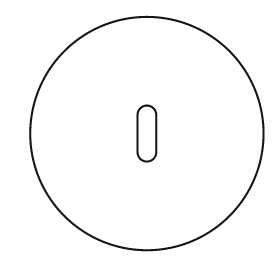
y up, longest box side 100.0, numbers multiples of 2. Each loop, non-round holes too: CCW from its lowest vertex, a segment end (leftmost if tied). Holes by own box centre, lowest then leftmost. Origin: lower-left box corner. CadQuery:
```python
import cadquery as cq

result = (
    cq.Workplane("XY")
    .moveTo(50.0, 50.0)
    .circle(50.0)
    .moveTo(46.0, 42.0)
    .threePointArc((50.0, 38.0), (54.0, 42.0))
    .lineTo(54.0, 58.0)
    .threePointArc((50.0, 62.0), (46.0, 58.0))
    .close()
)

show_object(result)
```